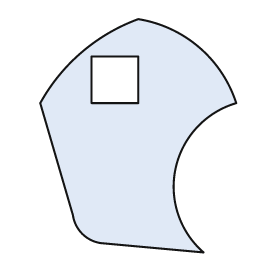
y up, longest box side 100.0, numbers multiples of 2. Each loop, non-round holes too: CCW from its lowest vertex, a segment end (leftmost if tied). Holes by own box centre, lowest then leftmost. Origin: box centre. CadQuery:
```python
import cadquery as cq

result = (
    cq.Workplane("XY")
    .moveTo(28.0, -50.0)
    .threePointArc((16.0, -14.0), (42.0, 14.0))
    .threePointArc((26.0, 38.0), (0.0, 50.0))
    .threePointArc((-24.0, 36.0), (-42.0, 14.0))
    .lineTo(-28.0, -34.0)
    .threePointArc((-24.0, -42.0), (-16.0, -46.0))
    .close()
    .moveTo(-20.0, 14.0)
    .lineTo(0.0, 14.0)
    .lineTo(0.0, 34.0)
    .lineTo(-20.0, 34.0)
    .close()
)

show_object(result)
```